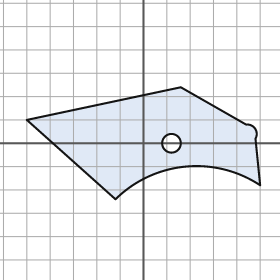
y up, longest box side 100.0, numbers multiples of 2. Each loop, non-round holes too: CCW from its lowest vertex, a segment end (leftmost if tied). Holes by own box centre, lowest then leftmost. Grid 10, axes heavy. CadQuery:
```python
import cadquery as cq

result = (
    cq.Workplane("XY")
    .moveTo(-12.0, -24.0)
    .threePointArc((18.0, -10.0), (50.0, -18.0))
    .lineTo(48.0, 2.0)
    .threePointArc((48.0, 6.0), (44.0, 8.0))
    .lineTo(16.0, 24.0)
    .lineTo(-50.0, 10.0)
    .close()
    .moveTo(12.0, 0.0)
    .circle(4.0)
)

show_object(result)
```